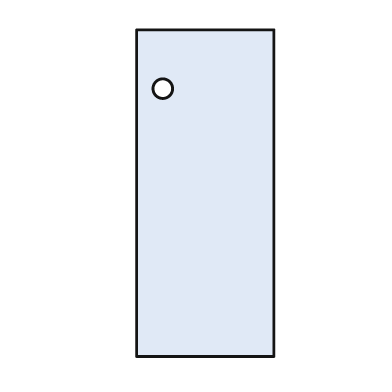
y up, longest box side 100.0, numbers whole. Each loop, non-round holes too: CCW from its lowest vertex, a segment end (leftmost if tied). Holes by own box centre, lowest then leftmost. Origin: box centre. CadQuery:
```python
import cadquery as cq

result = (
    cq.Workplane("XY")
    .moveTo(-21.0, -50.0)
    .lineTo(21.0, -50.0)
    .lineTo(21.0, 50.0)
    .lineTo(-21.0, 50.0)
    .close()
    .moveTo(-13.0, 32.0)
    .circle(3.0)
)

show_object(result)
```